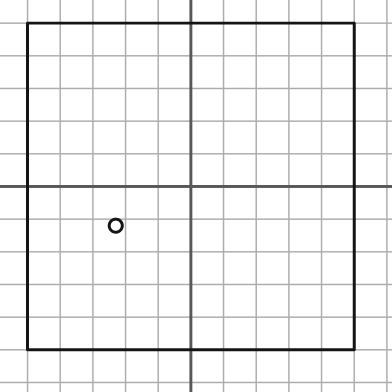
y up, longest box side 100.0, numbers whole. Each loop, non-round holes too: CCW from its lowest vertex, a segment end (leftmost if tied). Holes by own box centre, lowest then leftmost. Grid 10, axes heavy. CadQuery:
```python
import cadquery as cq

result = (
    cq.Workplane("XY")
    .moveTo(-50.0, -50.0)
    .lineTo(50.0, -50.0)
    .lineTo(50.0, 50.0)
    .lineTo(-50.0, 50.0)
    .close()
    .moveTo(-23.0, -12.0)
    .circle(2.0)
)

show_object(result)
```